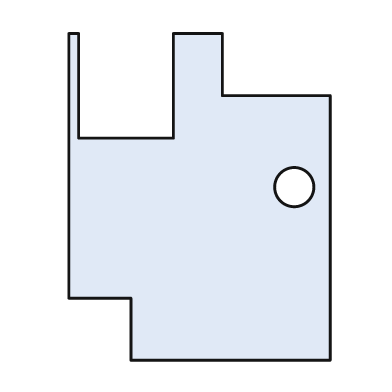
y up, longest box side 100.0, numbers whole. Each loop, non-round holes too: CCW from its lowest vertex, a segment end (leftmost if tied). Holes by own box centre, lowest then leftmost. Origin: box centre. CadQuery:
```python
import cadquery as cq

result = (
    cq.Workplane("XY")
    .moveTo(-21.0, -50.0)
    .lineTo(40.0, -50.0)
    .lineTo(40.0, 31.0)
    .lineTo(7.0, 31.0)
    .lineTo(7.0, 50.0)
    .lineTo(-8.0, 50.0)
    .lineTo(-8.0, 18.0)
    .lineTo(-37.0, 18.0)
    .lineTo(-37.0, 50.0)
    .lineTo(-40.0, 50.0)
    .lineTo(-40.0, -31.0)
    .lineTo(-21.0, -31.0)
    .close()
    .moveTo(29.0, 3.0)
    .circle(6.0)
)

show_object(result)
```